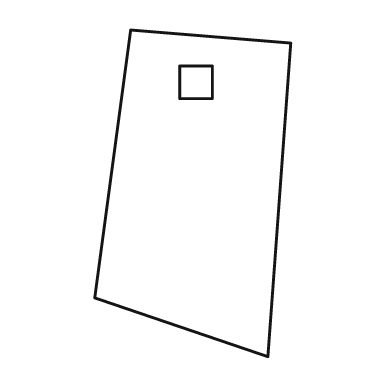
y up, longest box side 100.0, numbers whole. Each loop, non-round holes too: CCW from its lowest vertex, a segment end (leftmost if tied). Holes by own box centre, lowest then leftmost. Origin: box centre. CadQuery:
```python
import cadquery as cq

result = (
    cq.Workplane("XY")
    .moveTo(23.0, -50.0)
    .lineTo(30.0, 46.0)
    .lineTo(-19.0, 50.0)
    .lineTo(-30.0, -32.0)
    .close()
    .moveTo(-4.0, 29.0)
    .lineTo(6.0, 29.0)
    .lineTo(6.0, 39.0)
    .lineTo(-4.0, 39.0)
    .close()
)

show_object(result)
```